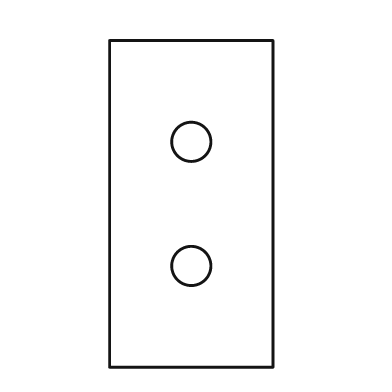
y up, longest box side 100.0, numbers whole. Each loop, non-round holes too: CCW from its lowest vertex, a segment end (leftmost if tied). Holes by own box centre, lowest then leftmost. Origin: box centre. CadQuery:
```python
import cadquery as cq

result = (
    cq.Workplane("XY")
    .moveTo(-25.0, -50.0)
    .lineTo(25.0, -50.0)
    .lineTo(25.0, 50.0)
    .lineTo(-25.0, 50.0)
    .close()
    .moveTo(0.0, -19.0)
    .circle(6.0)
    .moveTo(0.0, 19.0)
    .circle(6.0)
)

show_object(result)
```